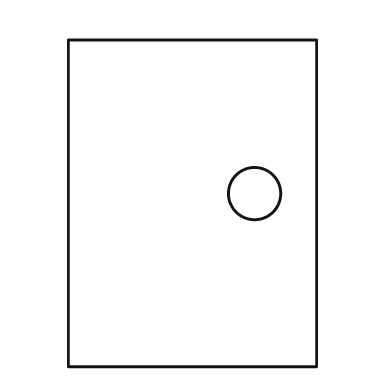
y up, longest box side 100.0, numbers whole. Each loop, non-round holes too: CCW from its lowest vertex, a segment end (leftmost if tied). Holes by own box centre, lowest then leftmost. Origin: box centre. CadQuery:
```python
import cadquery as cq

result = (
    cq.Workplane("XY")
    .moveTo(-38.0, -50.0)
    .lineTo(38.0, -50.0)
    .lineTo(38.0, 50.0)
    .lineTo(-38.0, 50.0)
    .close()
    .moveTo(19.0, 3.0)
    .circle(8.0)
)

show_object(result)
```